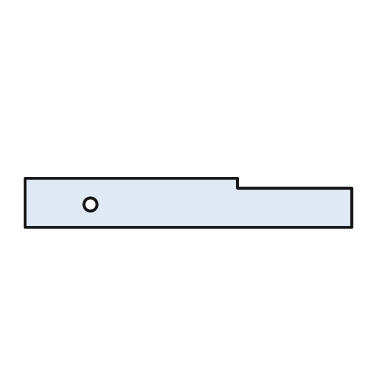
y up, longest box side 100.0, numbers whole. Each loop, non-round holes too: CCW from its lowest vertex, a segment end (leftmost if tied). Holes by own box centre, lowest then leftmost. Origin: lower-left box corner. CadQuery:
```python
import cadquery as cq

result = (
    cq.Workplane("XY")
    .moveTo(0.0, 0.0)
    .lineTo(100.0, 0.0)
    .lineTo(100.0, 12.0)
    .lineTo(65.0, 12.0)
    .lineTo(65.0, 15.0)
    .lineTo(0.0, 15.0)
    .close()
    .moveTo(20.0, 7.0)
    .circle(2.0)
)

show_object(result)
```